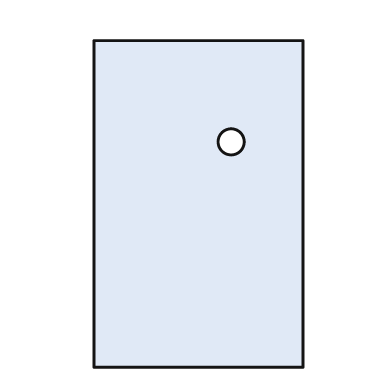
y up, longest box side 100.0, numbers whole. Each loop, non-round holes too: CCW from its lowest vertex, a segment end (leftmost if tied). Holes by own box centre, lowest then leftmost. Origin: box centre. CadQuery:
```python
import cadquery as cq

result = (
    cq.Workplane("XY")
    .moveTo(-32.0, -50.0)
    .lineTo(32.0, -50.0)
    .lineTo(32.0, 50.0)
    .lineTo(-32.0, 50.0)
    .close()
    .moveTo(10.0, 19.0)
    .circle(4.0)
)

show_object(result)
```